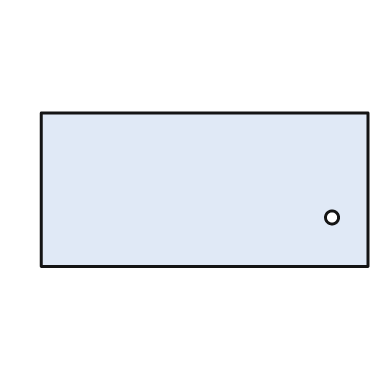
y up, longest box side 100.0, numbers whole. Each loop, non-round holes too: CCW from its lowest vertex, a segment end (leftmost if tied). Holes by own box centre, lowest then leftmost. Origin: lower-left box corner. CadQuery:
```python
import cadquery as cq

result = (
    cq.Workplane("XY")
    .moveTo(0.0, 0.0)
    .lineTo(100.0, 0.0)
    .lineTo(100.0, 47.0)
    .lineTo(0.0, 47.0)
    .close()
    .moveTo(89.0, 15.0)
    .circle(2.0)
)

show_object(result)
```